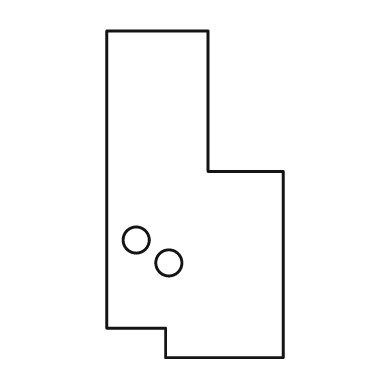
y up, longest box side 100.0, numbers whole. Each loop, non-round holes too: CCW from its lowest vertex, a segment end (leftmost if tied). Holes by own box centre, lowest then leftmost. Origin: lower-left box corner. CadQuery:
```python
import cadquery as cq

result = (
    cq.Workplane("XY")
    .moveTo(18.0, 0.0)
    .lineTo(54.0, 0.0)
    .lineTo(54.0, 57.0)
    .lineTo(31.0, 57.0)
    .lineTo(31.0, 100.0)
    .lineTo(0.0, 100.0)
    .lineTo(0.0, 9.0)
    .lineTo(18.0, 9.0)
    .close()
    .moveTo(19.0, 29.0)
    .circle(4.0)
    .moveTo(9.0, 36.0)
    .circle(4.0)
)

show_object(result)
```